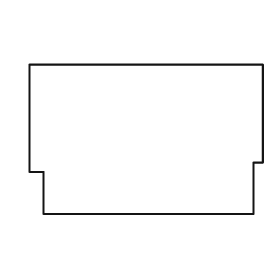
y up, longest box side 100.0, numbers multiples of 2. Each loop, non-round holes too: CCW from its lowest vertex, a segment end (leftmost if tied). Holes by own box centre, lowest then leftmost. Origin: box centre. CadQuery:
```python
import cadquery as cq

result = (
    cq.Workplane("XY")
    .moveTo(-44.0, -32.0)
    .lineTo(46.0, -32.0)
    .lineTo(46.0, -10.0)
    .lineTo(50.0, -10.0)
    .lineTo(50.0, 32.0)
    .lineTo(-50.0, 32.0)
    .lineTo(-50.0, -14.0)
    .lineTo(-44.0, -14.0)
    .close()
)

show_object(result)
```